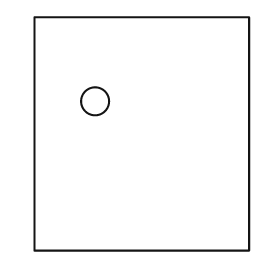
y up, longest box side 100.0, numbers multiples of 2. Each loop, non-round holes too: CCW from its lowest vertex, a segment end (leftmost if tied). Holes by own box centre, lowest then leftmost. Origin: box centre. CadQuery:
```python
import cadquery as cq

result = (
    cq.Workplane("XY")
    .moveTo(-46.0, -50.0)
    .lineTo(46.0, -50.0)
    .lineTo(46.0, 50.0)
    .lineTo(-46.0, 50.0)
    .close()
    .moveTo(-20.0, 14.0)
    .circle(6.0)
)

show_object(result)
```